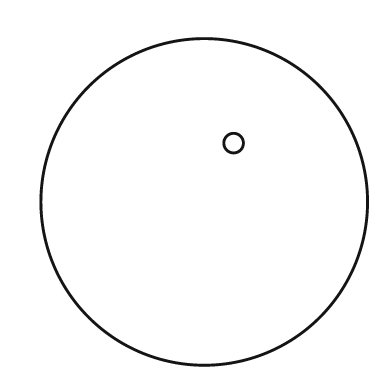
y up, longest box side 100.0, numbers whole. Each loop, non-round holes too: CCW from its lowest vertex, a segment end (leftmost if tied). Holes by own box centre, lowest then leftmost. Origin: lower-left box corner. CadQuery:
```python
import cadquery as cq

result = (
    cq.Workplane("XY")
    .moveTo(50.0, 50.0)
    .circle(50.0)
    .moveTo(59.0, 68.0)
    .circle(3.0)
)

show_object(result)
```